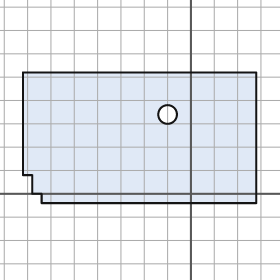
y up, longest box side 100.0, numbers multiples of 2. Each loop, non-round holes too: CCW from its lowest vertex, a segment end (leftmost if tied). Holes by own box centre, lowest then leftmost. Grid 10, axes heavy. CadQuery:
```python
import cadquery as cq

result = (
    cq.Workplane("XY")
    .moveTo(-64.0, -4.0)
    .lineTo(28.0, -4.0)
    .lineTo(28.0, 52.0)
    .lineTo(-72.0, 52.0)
    .lineTo(-72.0, 8.0)
    .lineTo(-68.0, 8.0)
    .lineTo(-68.0, 0.0)
    .lineTo(-64.0, 0.0)
    .close()
    .moveTo(-10.0, 34.0)
    .circle(4.0)
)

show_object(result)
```